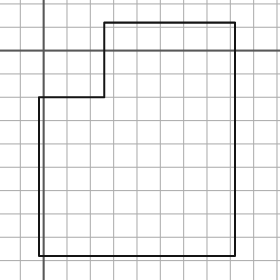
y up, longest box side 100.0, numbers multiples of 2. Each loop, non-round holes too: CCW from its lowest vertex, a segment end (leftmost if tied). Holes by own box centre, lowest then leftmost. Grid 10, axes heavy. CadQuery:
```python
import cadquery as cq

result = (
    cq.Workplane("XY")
    .moveTo(-2.0, -88.0)
    .lineTo(82.0, -88.0)
    .lineTo(82.0, 12.0)
    .lineTo(26.0, 12.0)
    .lineTo(26.0, -20.0)
    .lineTo(-2.0, -20.0)
    .close()
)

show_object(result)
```